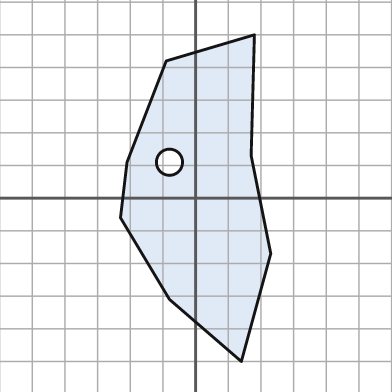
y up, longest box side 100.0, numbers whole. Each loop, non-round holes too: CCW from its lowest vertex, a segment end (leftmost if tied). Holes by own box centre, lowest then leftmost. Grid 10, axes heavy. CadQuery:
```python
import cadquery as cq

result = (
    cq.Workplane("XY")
    .moveTo(14.0, -50.0)
    .lineTo(23.0, -17.0)
    .lineTo(17.0, 13.0)
    .lineTo(18.0, 50.0)
    .lineTo(-9.0, 42.0)
    .lineTo(-21.0, 11.0)
    .lineTo(-23.0, -6.0)
    .lineTo(-8.0, -31.0)
    .close()
    .moveTo(-8.0, 11.0)
    .circle(4.0)
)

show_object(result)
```